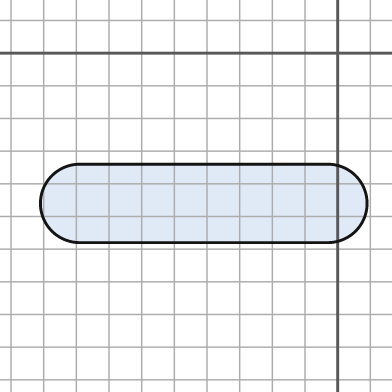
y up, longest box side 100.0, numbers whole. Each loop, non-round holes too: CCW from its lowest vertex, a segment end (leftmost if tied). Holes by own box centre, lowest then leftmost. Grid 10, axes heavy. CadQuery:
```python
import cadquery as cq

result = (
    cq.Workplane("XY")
    .moveTo(-79.0, -58.0)
    .lineTo(-3.0, -58.0)
    .threePointArc((9.0, -46.0), (-3.0, -34.0))
    .lineTo(-79.0, -34.0)
    .threePointArc((-91.0, -46.0), (-79.0, -58.0))
    .close()
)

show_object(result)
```